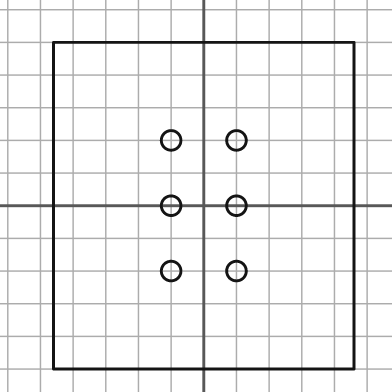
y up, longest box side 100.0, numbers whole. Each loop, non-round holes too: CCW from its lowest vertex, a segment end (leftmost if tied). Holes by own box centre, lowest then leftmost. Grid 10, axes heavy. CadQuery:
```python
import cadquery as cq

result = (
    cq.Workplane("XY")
    .moveTo(-46.0, -50.0)
    .lineTo(46.0, -50.0)
    .lineTo(46.0, 50.0)
    .lineTo(-46.0, 50.0)
    .close()
    .moveTo(-10.0, -20.0)
    .circle(3.0)
    .moveTo(10.0, -20.0)
    .circle(3.0)
    .moveTo(-10.0, 0.0)
    .circle(3.0)
    .moveTo(10.0, 0.0)
    .circle(3.0)
    .moveTo(-10.0, 20.0)
    .circle(3.0)
    .moveTo(10.0, 20.0)
    .circle(3.0)
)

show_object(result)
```